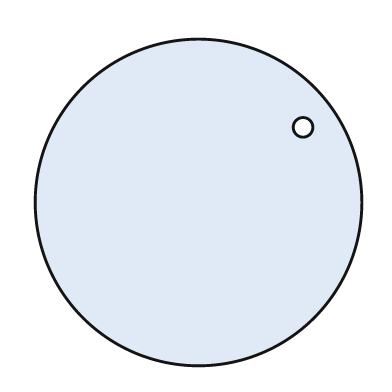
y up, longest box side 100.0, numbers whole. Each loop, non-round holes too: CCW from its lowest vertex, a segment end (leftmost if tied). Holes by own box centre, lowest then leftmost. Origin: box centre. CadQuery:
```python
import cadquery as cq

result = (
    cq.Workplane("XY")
    .moveTo(0.0, 0.0)
    .circle(50.0)
    .moveTo(32.0, 23.0)
    .circle(3.0)
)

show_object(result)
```